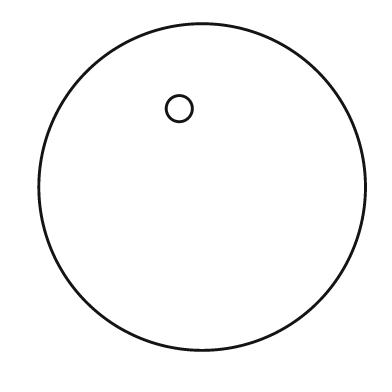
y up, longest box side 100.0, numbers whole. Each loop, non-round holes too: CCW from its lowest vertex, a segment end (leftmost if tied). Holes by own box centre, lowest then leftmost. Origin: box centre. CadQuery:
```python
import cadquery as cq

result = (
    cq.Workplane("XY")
    .moveTo(0.0, 0.0)
    .circle(50.0)
    .moveTo(-7.0, 24.0)
    .circle(4.0)
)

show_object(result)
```